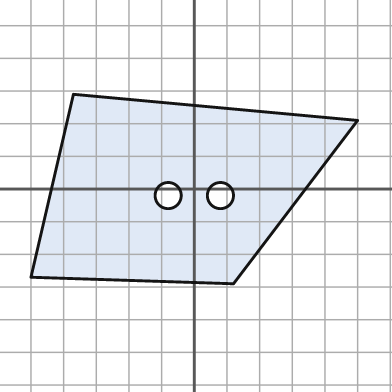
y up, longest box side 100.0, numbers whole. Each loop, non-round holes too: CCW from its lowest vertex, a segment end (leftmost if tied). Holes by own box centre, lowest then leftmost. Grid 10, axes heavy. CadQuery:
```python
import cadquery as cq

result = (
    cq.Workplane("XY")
    .moveTo(12.0, -29.0)
    .lineTo(50.0, 21.0)
    .lineTo(-37.0, 29.0)
    .lineTo(-50.0, -27.0)
    .close()
    .moveTo(-8.0, -2.0)
    .circle(4.0)
    .moveTo(8.0, -2.0)
    .circle(4.0)
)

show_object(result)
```